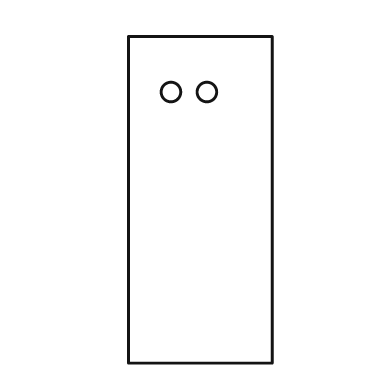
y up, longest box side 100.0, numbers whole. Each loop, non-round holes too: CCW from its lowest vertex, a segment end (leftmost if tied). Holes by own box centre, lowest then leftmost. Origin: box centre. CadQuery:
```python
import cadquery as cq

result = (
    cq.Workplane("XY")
    .moveTo(-22.0, -50.0)
    .lineTo(22.0, -50.0)
    .lineTo(22.0, 50.0)
    .lineTo(-22.0, 50.0)
    .close()
    .moveTo(-9.0, 33.0)
    .circle(3.0)
    .moveTo(2.0, 33.0)
    .circle(3.0)
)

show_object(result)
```